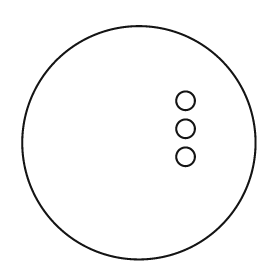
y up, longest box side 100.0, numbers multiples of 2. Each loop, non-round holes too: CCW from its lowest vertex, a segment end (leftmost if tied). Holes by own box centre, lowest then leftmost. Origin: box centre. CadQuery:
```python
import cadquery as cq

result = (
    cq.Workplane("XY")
    .moveTo(0.0, 0.0)
    .circle(50.0)
    .moveTo(20.0, -6.0)
    .circle(4.0)
    .moveTo(20.0, 6.0)
    .circle(4.0)
    .moveTo(20.0, 18.0)
    .circle(4.0)
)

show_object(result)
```